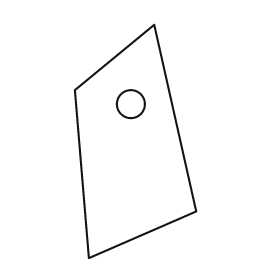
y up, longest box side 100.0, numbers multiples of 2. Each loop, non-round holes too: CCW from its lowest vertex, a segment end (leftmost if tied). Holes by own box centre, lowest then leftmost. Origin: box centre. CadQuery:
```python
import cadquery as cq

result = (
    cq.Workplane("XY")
    .moveTo(-20.0, -50.0)
    .lineTo(26.0, -30.0)
    .lineTo(8.0, 50.0)
    .lineTo(-26.0, 22.0)
    .close()
    .moveTo(-2.0, 16.0)
    .circle(6.0)
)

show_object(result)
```